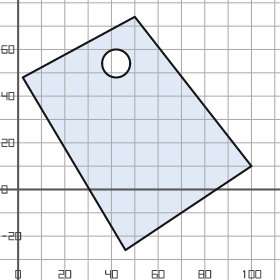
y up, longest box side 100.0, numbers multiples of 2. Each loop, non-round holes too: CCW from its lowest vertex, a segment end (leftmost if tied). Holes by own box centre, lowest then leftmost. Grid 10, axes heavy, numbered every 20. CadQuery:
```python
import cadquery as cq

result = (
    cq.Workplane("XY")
    .moveTo(46.0, -26.0)
    .lineTo(100.0, 10.0)
    .lineTo(50.0, 74.0)
    .lineTo(2.0, 48.0)
    .close()
    .moveTo(42.0, 54.0)
    .circle(6.0)
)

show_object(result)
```